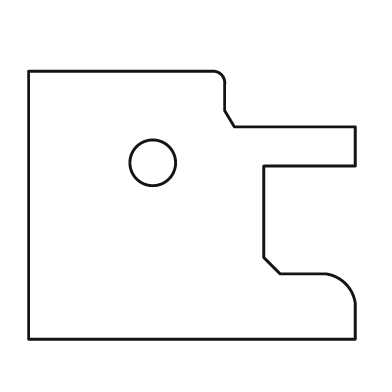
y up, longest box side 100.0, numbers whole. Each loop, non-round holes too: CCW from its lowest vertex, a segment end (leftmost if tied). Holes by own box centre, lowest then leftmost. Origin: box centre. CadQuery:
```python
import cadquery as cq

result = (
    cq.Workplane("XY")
    .moveTo(-50.0, -41.0)
    .lineTo(50.0, -41.0)
    .lineTo(50.0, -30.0)
    .threePointArc((47.0, -24.0), (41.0, -21.0))
    .lineTo(27.0, -21.0)
    .lineTo(22.0, -16.0)
    .lineTo(22.0, 12.0)
    .lineTo(50.0, 12.0)
    .lineTo(50.0, 24.0)
    .lineTo(13.0, 24.0)
    .lineTo(10.0, 29.0)
    .lineTo(10.0, 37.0)
    .threePointArc((9.0, 40.0), (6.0, 41.0))
    .lineTo(-50.0, 41.0)
    .close()
    .moveTo(-12.0, 13.0)
    .circle(7.0)
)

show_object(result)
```